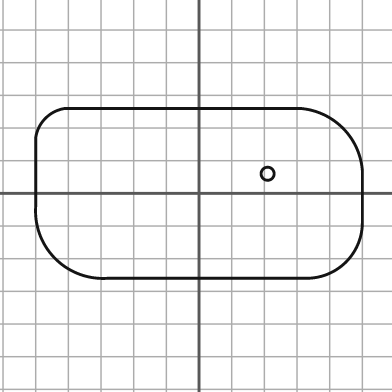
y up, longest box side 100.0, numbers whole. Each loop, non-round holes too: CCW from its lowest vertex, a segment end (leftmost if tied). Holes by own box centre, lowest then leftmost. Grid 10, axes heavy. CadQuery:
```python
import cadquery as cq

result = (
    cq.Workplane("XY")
    .moveTo(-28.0, -26.0)
    .lineTo(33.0, -26.0)
    .threePointArc((45.0, -21.0), (50.0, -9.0))
    .lineTo(50.0, 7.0)
    .threePointArc((44.0, 20.0), (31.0, 26.0))
    .lineTo(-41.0, 26.0)
    .threePointArc((-47.0, 23.0), (-50.0, 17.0))
    .lineTo(-50.0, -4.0)
    .threePointArc((-44.0, -20.0), (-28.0, -26.0))
    .close()
    .moveTo(21.0, 6.0)
    .circle(2.0)
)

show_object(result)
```